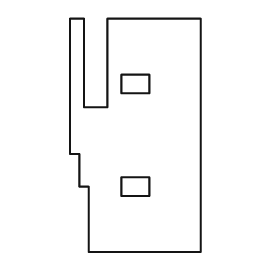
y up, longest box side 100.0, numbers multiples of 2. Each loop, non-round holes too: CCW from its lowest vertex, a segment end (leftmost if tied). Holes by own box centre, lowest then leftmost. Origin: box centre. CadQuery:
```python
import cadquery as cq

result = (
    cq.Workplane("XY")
    .moveTo(-20.0, -50.0)
    .lineTo(28.0, -50.0)
    .lineTo(28.0, 50.0)
    .lineTo(-12.0, 50.0)
    .lineTo(-12.0, 12.0)
    .lineTo(-22.0, 12.0)
    .lineTo(-22.0, 50.0)
    .lineTo(-28.0, 50.0)
    .lineTo(-28.0, -8.0)
    .lineTo(-24.0, -8.0)
    .lineTo(-24.0, -22.0)
    .lineTo(-20.0, -22.0)
    .close()
    .moveTo(-6.0, -26.0)
    .lineTo(6.0, -26.0)
    .lineTo(6.0, -18.0)
    .lineTo(-6.0, -18.0)
    .close()
    .moveTo(-6.0, 18.0)
    .lineTo(6.0, 18.0)
    .lineTo(6.0, 26.0)
    .lineTo(-6.0, 26.0)
    .close()
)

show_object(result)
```